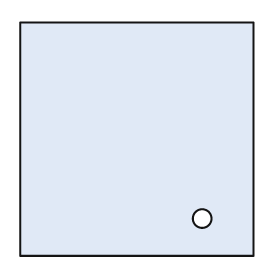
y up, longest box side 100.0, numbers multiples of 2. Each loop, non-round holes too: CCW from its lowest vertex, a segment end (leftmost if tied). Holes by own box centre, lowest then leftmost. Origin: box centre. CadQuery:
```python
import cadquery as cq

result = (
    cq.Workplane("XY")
    .moveTo(-50.0, -50.0)
    .lineTo(50.0, -50.0)
    .lineTo(50.0, 50.0)
    .lineTo(-50.0, 50.0)
    .close()
    .moveTo(28.0, -34.0)
    .circle(4.0)
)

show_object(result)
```